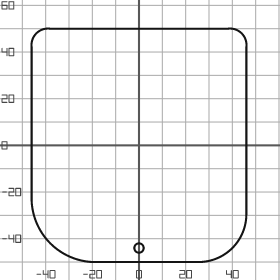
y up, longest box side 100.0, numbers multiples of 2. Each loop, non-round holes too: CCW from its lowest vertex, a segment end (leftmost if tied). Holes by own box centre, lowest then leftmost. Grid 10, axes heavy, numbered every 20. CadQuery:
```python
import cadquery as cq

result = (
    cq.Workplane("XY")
    .moveTo(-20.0, -50.0)
    .lineTo(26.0, -50.0)
    .threePointArc((40.0, -44.0), (46.0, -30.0))
    .lineTo(46.0, 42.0)
    .threePointArc((44.0, 48.0), (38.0, 50.0))
    .lineTo(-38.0, 50.0)
    .threePointArc((-44.0, 48.0), (-46.0, 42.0))
    .lineTo(-46.0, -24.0)
    .threePointArc((-38.0, -42.0), (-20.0, -50.0))
    .close()
    .moveTo(0.0, -44.0)
    .circle(2.0)
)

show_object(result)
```